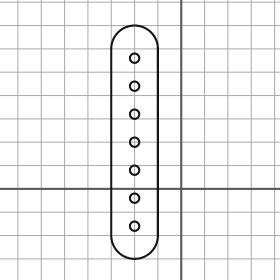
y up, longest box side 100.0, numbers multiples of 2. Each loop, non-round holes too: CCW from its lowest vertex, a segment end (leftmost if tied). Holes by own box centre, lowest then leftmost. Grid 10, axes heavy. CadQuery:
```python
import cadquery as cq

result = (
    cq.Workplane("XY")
    .moveTo(-30.0, -20.0)
    .threePointArc((-20.0, -30.0), (-10.0, -20.0))
    .lineTo(-10.0, 60.0)
    .threePointArc((-20.0, 70.0), (-30.0, 60.0))
    .close()
    .moveTo(-20.0, -16.0)
    .circle(2.0)
    .moveTo(-20.0, -4.0)
    .circle(2.0)
    .moveTo(-20.0, 8.0)
    .circle(2.0)
    .moveTo(-20.0, 20.0)
    .circle(2.0)
    .moveTo(-20.0, 32.0)
    .circle(2.0)
    .moveTo(-20.0, 44.0)
    .circle(2.0)
    .moveTo(-20.0, 56.0)
    .circle(2.0)
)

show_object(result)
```